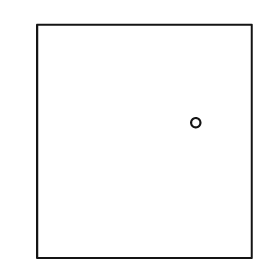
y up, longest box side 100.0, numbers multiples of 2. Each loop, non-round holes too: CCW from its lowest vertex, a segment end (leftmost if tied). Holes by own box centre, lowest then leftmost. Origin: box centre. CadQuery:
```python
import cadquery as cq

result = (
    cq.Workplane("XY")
    .moveTo(-46.0, -50.0)
    .lineTo(46.0, -50.0)
    .lineTo(46.0, 50.0)
    .lineTo(-46.0, 50.0)
    .close()
    .moveTo(22.0, 8.0)
    .circle(2.0)
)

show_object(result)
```